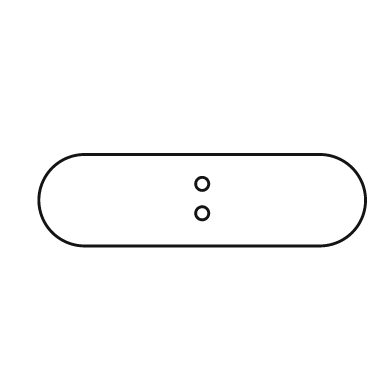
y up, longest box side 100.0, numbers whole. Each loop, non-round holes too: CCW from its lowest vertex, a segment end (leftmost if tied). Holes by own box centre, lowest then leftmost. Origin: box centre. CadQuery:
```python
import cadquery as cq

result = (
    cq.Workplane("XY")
    .moveTo(-36.0, -14.0)
    .lineTo(36.0, -14.0)
    .threePointArc((50.0, 0.0), (36.0, 14.0))
    .lineTo(-36.0, 14.0)
    .threePointArc((-50.0, 0.0), (-36.0, -14.0))
    .close()
    .moveTo(0.0, -4.0)
    .circle(2.0)
    .moveTo(0.0, 5.0)
    .circle(2.0)
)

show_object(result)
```